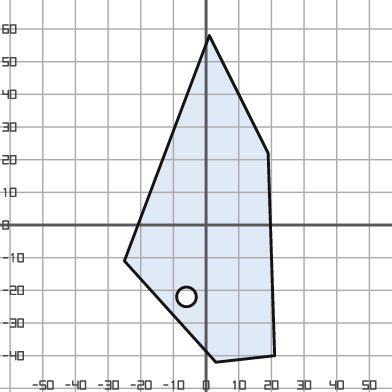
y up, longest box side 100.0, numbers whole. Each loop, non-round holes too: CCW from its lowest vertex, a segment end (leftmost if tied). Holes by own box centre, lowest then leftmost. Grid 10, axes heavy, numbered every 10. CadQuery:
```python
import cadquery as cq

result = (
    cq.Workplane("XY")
    .moveTo(3.0, -42.0)
    .lineTo(21.0, -40.0)
    .lineTo(19.0, 22.0)
    .lineTo(1.0, 58.0)
    .lineTo(-25.0, -11.0)
    .close()
    .moveTo(-6.0, -22.0)
    .circle(3.0)
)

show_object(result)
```